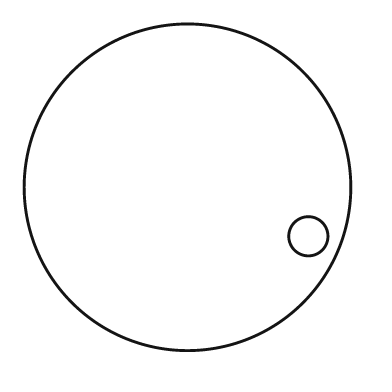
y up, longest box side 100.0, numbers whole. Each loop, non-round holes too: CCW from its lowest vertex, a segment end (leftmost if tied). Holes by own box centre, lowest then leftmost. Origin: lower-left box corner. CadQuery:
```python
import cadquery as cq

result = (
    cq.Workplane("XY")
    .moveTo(50.0, 50.0)
    .circle(50.0)
    .moveTo(87.0, 35.0)
    .circle(6.0)
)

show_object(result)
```